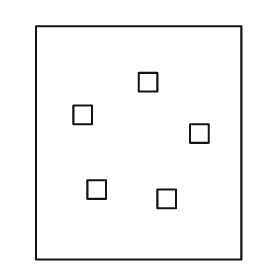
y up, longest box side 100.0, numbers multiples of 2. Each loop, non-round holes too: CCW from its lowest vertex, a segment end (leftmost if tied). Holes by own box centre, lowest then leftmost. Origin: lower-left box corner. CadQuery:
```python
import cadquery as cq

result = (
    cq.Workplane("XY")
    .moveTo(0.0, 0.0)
    .lineTo(88.0, 0.0)
    .lineTo(88.0, 100.0)
    .lineTo(0.0, 100.0)
    .close()
    .moveTo(52.0, 22.0)
    .lineTo(60.0, 22.0)
    .lineTo(60.0, 30.0)
    .lineTo(52.0, 30.0)
    .close()
    .moveTo(22.0, 26.0)
    .lineTo(30.0, 26.0)
    .lineTo(30.0, 34.0)
    .lineTo(22.0, 34.0)
    .close()
    .moveTo(66.0, 50.0)
    .lineTo(74.0, 50.0)
    .lineTo(74.0, 58.0)
    .lineTo(66.0, 58.0)
    .close()
    .moveTo(16.0, 58.0)
    .lineTo(24.0, 58.0)
    .lineTo(24.0, 66.0)
    .lineTo(16.0, 66.0)
    .close()
    .moveTo(44.0, 72.0)
    .lineTo(52.0, 72.0)
    .lineTo(52.0, 80.0)
    .lineTo(44.0, 80.0)
    .close()
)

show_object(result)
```